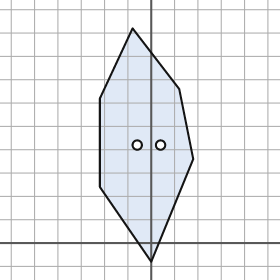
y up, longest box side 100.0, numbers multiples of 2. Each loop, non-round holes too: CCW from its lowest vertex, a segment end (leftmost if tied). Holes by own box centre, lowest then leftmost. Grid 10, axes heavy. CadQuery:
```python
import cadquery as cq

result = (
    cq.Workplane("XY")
    .moveTo(0.0, -8.0)
    .lineTo(18.0, 36.0)
    .lineTo(12.0, 66.0)
    .lineTo(-8.0, 92.0)
    .lineTo(-22.0, 62.0)
    .lineTo(-22.0, 24.0)
    .close()
    .moveTo(-6.0, 42.0)
    .circle(2.0)
    .moveTo(4.0, 42.0)
    .circle(2.0)
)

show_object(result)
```